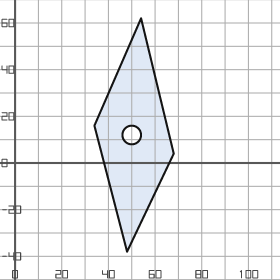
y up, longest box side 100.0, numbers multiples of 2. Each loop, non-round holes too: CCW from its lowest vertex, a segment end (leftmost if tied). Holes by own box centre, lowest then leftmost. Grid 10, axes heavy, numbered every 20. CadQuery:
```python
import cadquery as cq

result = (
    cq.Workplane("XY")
    .moveTo(48.0, -38.0)
    .lineTo(68.0, 4.0)
    .lineTo(54.0, 62.0)
    .lineTo(34.0, 16.0)
    .close()
    .moveTo(50.0, 12.0)
    .circle(4.0)
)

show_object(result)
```